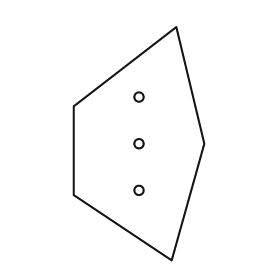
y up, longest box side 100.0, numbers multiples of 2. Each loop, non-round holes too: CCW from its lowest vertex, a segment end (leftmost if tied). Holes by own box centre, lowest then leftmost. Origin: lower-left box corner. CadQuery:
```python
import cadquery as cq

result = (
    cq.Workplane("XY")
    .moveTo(42.0, 0.0)
    .lineTo(56.0, 50.0)
    .lineTo(44.0, 100.0)
    .lineTo(0.0, 66.0)
    .lineTo(0.0, 28.0)
    .close()
    .moveTo(28.0, 30.0)
    .circle(2.0)
    .moveTo(28.0, 50.0)
    .circle(2.0)
    .moveTo(28.0, 70.0)
    .circle(2.0)
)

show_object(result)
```